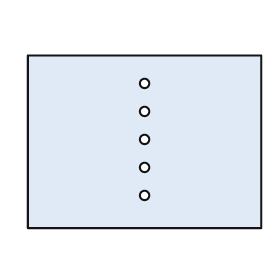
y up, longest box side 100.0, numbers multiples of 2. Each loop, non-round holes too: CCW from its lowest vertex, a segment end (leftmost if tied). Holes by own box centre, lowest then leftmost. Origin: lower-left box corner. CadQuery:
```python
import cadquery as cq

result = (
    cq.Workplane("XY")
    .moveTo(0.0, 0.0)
    .lineTo(100.0, 0.0)
    .lineTo(100.0, 74.0)
    .lineTo(0.0, 74.0)
    .close()
    .moveTo(50.0, 14.0)
    .circle(2.0)
    .moveTo(50.0, 26.0)
    .circle(2.0)
    .moveTo(50.0, 38.0)
    .circle(2.0)
    .moveTo(50.0, 50.0)
    .circle(2.0)
    .moveTo(50.0, 62.0)
    .circle(2.0)
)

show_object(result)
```